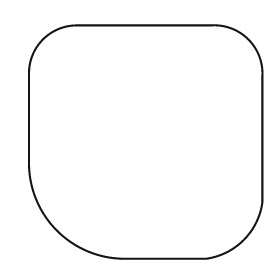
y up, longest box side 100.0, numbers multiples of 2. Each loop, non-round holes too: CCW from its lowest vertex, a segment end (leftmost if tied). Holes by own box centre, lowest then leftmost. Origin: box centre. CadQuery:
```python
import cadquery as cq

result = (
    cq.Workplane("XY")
    .moveTo(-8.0, -50.0)
    .lineTo(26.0, -50.0)
    .threePointArc((42.0, -42.0), (50.0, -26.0))
    .lineTo(50.0, 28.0)
    .threePointArc((44.0, 44.0), (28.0, 50.0))
    .lineTo(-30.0, 50.0)
    .threePointArc((-44.0, 44.0), (-50.0, 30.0))
    .lineTo(-50.0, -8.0)
    .threePointArc((-38.0, -38.0), (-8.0, -50.0))
    .close()
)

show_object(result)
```